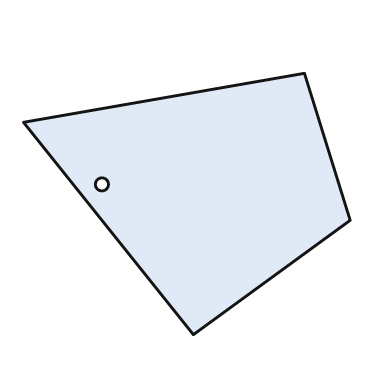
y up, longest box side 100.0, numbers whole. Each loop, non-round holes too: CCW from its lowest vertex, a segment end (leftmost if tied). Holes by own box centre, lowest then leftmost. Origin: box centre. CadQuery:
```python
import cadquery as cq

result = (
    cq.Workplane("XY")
    .moveTo(2.0, -40.0)
    .lineTo(50.0, -5.0)
    .lineTo(36.0, 40.0)
    .lineTo(-50.0, 25.0)
    .close()
    .moveTo(-26.0, 6.0)
    .circle(2.0)
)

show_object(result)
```